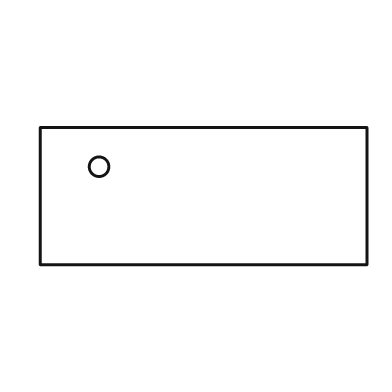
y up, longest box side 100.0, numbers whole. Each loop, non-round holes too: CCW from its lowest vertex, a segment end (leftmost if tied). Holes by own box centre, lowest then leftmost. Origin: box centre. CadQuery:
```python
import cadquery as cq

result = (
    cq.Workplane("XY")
    .moveTo(-50.0, -21.0)
    .lineTo(50.0, -21.0)
    .lineTo(50.0, 21.0)
    .lineTo(-50.0, 21.0)
    .close()
    .moveTo(-32.0, 9.0)
    .circle(3.0)
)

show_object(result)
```